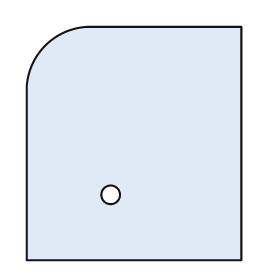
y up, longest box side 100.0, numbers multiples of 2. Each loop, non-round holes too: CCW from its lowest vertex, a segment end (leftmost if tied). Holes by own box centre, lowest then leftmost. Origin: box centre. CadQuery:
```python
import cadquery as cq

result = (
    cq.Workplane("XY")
    .moveTo(-46.0, -50.0)
    .lineTo(46.0, -50.0)
    .lineTo(46.0, 50.0)
    .lineTo(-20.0, 50.0)
    .threePointArc((-38.0, 42.0), (-46.0, 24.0))
    .close()
    .moveTo(-10.0, -22.0)
    .circle(4.0)
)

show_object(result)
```